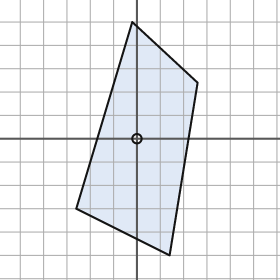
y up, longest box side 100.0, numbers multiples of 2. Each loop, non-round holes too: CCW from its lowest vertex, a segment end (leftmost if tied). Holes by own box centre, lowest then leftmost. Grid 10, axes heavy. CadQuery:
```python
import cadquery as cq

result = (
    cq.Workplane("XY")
    .moveTo(14.0, -50.0)
    .lineTo(26.0, 24.0)
    .lineTo(-2.0, 50.0)
    .lineTo(-26.0, -30.0)
    .close()
    .moveTo(0.0, 0.0)
    .circle(2.0)
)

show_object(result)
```